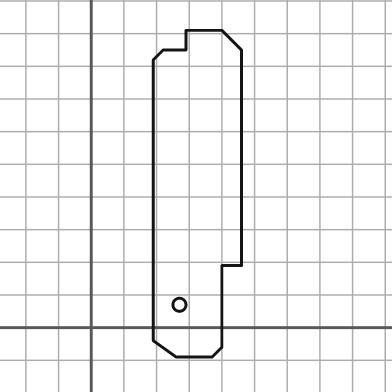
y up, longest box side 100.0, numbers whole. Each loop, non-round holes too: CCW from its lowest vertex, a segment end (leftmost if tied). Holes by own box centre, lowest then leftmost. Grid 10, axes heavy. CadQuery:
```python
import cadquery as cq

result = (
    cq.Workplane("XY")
    .moveTo(26.0, -9.0)
    .lineTo(37.0, -9.0)
    .lineTo(40.0, -6.0)
    .lineTo(40.0, 19.0)
    .lineTo(46.0, 19.0)
    .lineTo(46.0, 85.0)
    .lineTo(40.0, 91.0)
    .lineTo(29.0, 91.0)
    .lineTo(29.0, 85.0)
    .lineTo(22.0, 85.0)
    .lineTo(19.0, 82.0)
    .lineTo(19.0, -4.0)
    .close()
    .moveTo(27.0, 7.0)
    .circle(2.0)
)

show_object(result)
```